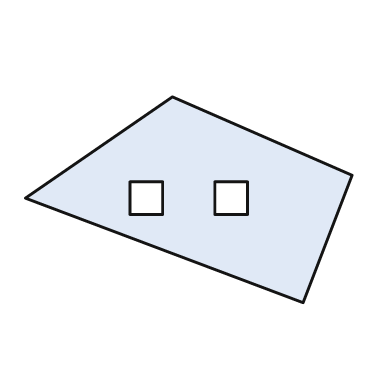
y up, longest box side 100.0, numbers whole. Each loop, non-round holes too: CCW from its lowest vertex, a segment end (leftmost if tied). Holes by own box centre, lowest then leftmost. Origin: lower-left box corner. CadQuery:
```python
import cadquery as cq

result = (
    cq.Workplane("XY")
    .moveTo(85.0, 0.0)
    .lineTo(100.0, 39.0)
    .lineTo(45.0, 63.0)
    .lineTo(0.0, 32.0)
    .close()
    .moveTo(32.0, 27.0)
    .lineTo(42.0, 27.0)
    .lineTo(42.0, 37.0)
    .lineTo(32.0, 37.0)
    .close()
    .moveTo(58.0, 27.0)
    .lineTo(68.0, 27.0)
    .lineTo(68.0, 37.0)
    .lineTo(58.0, 37.0)
    .close()
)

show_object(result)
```